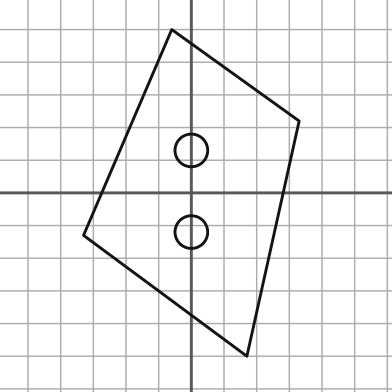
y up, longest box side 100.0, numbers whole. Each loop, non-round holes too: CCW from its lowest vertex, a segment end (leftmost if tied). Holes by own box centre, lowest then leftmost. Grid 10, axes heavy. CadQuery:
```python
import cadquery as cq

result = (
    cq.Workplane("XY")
    .moveTo(17.0, -50.0)
    .lineTo(33.0, 22.0)
    .lineTo(-6.0, 50.0)
    .lineTo(-33.0, -13.0)
    .close()
    .moveTo(0.0, -12.0)
    .circle(5.0)
    .moveTo(0.0, 13.0)
    .circle(5.0)
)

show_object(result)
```